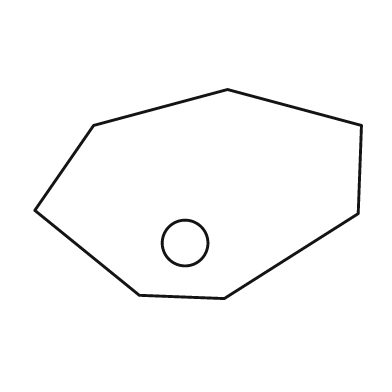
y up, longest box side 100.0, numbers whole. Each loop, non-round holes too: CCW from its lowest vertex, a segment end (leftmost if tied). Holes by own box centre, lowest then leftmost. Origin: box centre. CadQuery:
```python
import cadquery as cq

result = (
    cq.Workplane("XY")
    .moveTo(8.0, -32.0)
    .lineTo(49.0, -6.0)
    .lineTo(50.0, 21.0)
    .lineTo(9.0, 32.0)
    .lineTo(-32.0, 21.0)
    .lineTo(-50.0, -5.0)
    .lineTo(-18.0, -31.0)
    .close()
    .moveTo(-4.0, -15.0)
    .circle(7.0)
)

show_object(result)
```